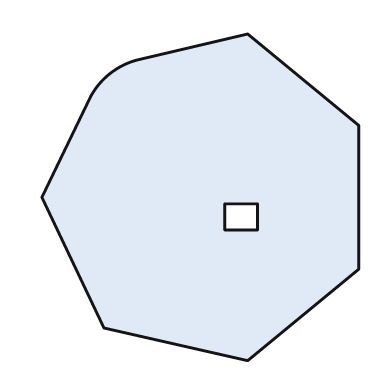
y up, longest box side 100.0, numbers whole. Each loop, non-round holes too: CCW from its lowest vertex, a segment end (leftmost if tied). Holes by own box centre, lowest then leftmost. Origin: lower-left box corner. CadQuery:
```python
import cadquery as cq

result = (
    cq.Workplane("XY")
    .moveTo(63.0, 0.0)
    .lineTo(97.0, 28.0)
    .lineTo(97.0, 72.0)
    .lineTo(63.0, 100.0)
    .lineTo(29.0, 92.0)
    .threePointArc((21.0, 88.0), (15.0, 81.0))
    .lineTo(0.0, 50.0)
    .lineTo(19.0, 10.0)
    .close()
    .moveTo(56.0, 40.0)
    .lineTo(66.0, 40.0)
    .lineTo(66.0, 48.0)
    .lineTo(56.0, 48.0)
    .close()
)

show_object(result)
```